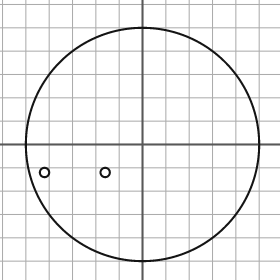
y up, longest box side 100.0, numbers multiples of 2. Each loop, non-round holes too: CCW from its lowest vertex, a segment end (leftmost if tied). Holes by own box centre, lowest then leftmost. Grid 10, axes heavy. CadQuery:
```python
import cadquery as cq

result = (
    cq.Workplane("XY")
    .moveTo(0.0, 0.0)
    .circle(50.0)
    .moveTo(-42.0, -12.0)
    .circle(2.0)
    .moveTo(-16.0, -12.0)
    .circle(2.0)
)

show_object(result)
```